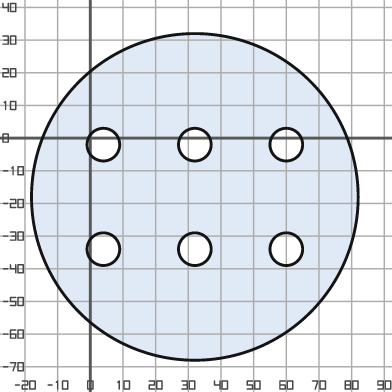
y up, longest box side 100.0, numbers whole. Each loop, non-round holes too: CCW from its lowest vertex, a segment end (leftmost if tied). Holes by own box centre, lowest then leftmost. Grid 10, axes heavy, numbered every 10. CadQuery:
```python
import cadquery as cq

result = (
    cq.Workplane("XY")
    .moveTo(32.0, -18.0)
    .circle(50.0)
    .moveTo(4.0, -34.0)
    .circle(5.0)
    .moveTo(32.0, -34.0)
    .circle(5.0)
    .moveTo(60.0, -34.0)
    .circle(5.0)
    .moveTo(4.0, -2.0)
    .circle(5.0)
    .moveTo(32.0, -2.0)
    .circle(5.0)
    .moveTo(60.0, -2.0)
    .circle(5.0)
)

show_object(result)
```